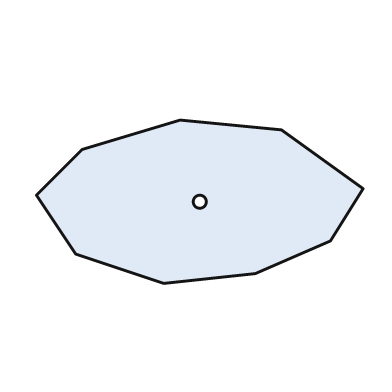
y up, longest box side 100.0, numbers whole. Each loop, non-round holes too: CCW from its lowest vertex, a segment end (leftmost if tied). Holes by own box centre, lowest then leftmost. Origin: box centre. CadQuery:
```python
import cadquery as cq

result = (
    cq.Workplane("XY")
    .moveTo(-11.0, -25.0)
    .lineTo(17.0, -22.0)
    .lineTo(40.0, -12.0)
    .lineTo(50.0, 4.0)
    .lineTo(25.0, 22.0)
    .lineTo(-6.0, 25.0)
    .lineTo(-36.0, 16.0)
    .lineTo(-50.0, 2.0)
    .lineTo(-38.0, -16.0)
    .close()
    .moveTo(0.0, 0.0)
    .circle(2.0)
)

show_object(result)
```